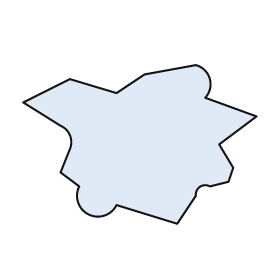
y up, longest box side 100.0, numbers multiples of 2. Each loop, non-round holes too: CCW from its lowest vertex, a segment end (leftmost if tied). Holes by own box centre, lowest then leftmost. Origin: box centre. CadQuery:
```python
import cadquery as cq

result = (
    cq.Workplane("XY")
    .moveTo(16.0, -34.0)
    .lineTo(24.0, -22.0)
    .threePointArc((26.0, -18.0), (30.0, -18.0))
    .lineTo(38.0, -16.0)
    .lineTo(40.0, -10.0)
    .lineTo(34.0, 0.0)
    .lineTo(50.0, 12.0)
    .lineTo(28.0, 20.0)
    .threePointArc((30.0, 28.0), (24.0, 34.0))
    .lineTo(2.0, 30.0)
    .lineTo(-10.0, 22.0)
    .lineTo(-30.0, 28.0)
    .lineTo(-50.0, 18.0)
    .lineTo(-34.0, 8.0)
    .threePointArc((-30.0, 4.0), (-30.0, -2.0))
    .lineTo(-34.0, -12.0)
    .lineTo(-26.0, -18.0)
    .threePointArc((-22.0, -30.0), (-10.0, -26.0))
    .close()
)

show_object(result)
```